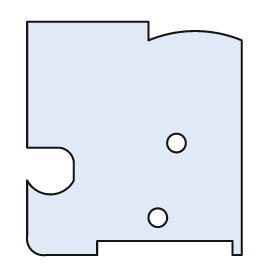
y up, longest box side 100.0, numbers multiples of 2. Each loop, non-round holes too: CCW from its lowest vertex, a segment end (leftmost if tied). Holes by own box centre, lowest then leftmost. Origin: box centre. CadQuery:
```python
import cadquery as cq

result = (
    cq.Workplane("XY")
    .moveTo(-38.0, -50.0)
    .lineTo(-16.0, -50.0)
    .lineTo(-16.0, -44.0)
    .lineTo(42.0, -44.0)
    .lineTo(42.0, -50.0)
    .lineTo(46.0, -50.0)
    .lineTo(46.0, 42.0)
    .threePointArc((26.0, 46.0), (6.0, 42.0))
    .lineTo(6.0, 50.0)
    .lineTo(-46.0, 50.0)
    .lineTo(-46.0, -4.0)
    .lineTo(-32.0, -4.0)
    .threePointArc((-28.0, -6.0), (-26.0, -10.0))
    .lineTo(-26.0, -18.0)
    .threePointArc((-36.0, -24.0), (-46.0, -18.0))
    .lineTo(-46.0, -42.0)
    .threePointArc((-44.0, -48.0), (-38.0, -50.0))
    .close()
    .moveTo(10.0, -34.0)
    .circle(4.0)
    .moveTo(18.0, -2.0)
    .circle(4.0)
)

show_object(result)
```